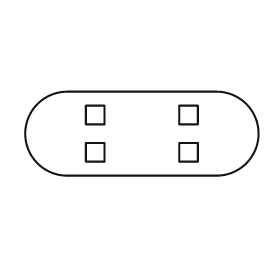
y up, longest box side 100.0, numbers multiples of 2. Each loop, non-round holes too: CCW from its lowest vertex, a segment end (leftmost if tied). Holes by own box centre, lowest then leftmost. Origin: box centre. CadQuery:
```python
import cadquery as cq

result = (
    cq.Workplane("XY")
    .moveTo(-32.0, -18.0)
    .lineTo(32.0, -18.0)
    .threePointArc((50.0, 0.0), (32.0, 18.0))
    .lineTo(-32.0, 18.0)
    .threePointArc((-50.0, 0.0), (-32.0, -18.0))
    .close()
    .moveTo(-24.0, -12.0)
    .lineTo(-16.0, -12.0)
    .lineTo(-16.0, -4.0)
    .lineTo(-24.0, -4.0)
    .close()
    .moveTo(16.0, -12.0)
    .lineTo(24.0, -12.0)
    .lineTo(24.0, -4.0)
    .lineTo(16.0, -4.0)
    .close()
    .moveTo(-24.0, 4.0)
    .lineTo(-16.0, 4.0)
    .lineTo(-16.0, 12.0)
    .lineTo(-24.0, 12.0)
    .close()
    .moveTo(16.0, 4.0)
    .lineTo(24.0, 4.0)
    .lineTo(24.0, 12.0)
    .lineTo(16.0, 12.0)
    .close()
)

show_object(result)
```